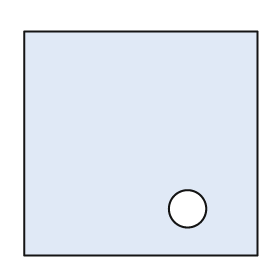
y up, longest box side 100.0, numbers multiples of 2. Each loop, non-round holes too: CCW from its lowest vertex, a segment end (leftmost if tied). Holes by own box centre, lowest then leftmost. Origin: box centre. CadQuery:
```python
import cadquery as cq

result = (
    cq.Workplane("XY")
    .moveTo(-50.0, -48.0)
    .lineTo(50.0, -48.0)
    .lineTo(50.0, 48.0)
    .lineTo(-50.0, 48.0)
    .close()
    .moveTo(20.0, -28.0)
    .circle(8.0)
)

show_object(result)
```